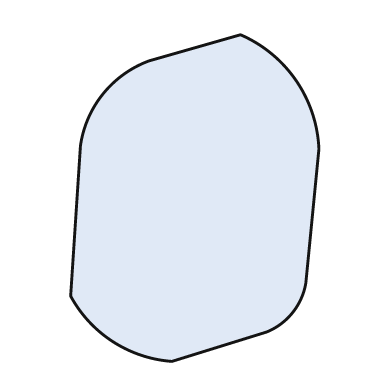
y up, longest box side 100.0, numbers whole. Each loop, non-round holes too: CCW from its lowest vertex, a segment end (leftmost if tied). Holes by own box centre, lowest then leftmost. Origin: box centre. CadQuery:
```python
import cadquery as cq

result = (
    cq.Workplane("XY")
    .moveTo(-7.0, -50.0)
    .lineTo(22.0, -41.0)
    .threePointArc((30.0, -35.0), (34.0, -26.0))
    .lineTo(38.0, 15.0)
    .threePointArc((31.0, 36.0), (14.0, 50.0))
    .lineTo(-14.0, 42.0)
    .threePointArc((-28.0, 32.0), (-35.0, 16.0))
    .lineTo(-38.0, -30.0)
    .threePointArc((-25.0, -44.0), (-7.0, -50.0))
    .close()
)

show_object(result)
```